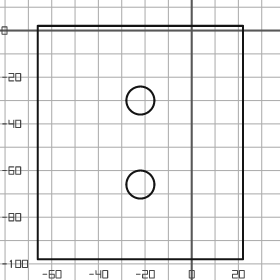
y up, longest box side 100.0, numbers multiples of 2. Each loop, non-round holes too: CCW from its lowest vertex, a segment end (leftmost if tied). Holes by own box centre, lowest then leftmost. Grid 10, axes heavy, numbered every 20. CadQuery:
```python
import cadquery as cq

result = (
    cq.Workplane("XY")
    .moveTo(-66.0, -98.0)
    .lineTo(22.0, -98.0)
    .lineTo(22.0, 2.0)
    .lineTo(-66.0, 2.0)
    .close()
    .moveTo(-22.0, -66.0)
    .circle(6.0)
    .moveTo(-22.0, -30.0)
    .circle(6.0)
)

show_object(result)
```